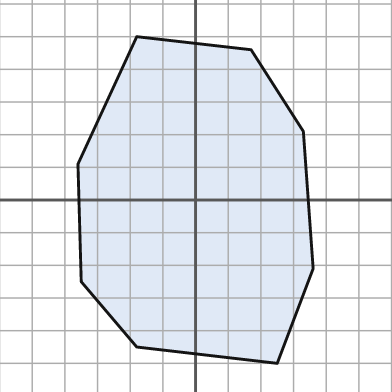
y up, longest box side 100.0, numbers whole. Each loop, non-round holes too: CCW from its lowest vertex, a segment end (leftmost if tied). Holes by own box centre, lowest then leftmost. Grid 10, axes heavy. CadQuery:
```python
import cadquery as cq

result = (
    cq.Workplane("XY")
    .moveTo(25.0, -50.0)
    .lineTo(36.0, -21.0)
    .lineTo(33.0, 21.0)
    .lineTo(17.0, 46.0)
    .lineTo(-18.0, 50.0)
    .lineTo(-36.0, 11.0)
    .lineTo(-35.0, -25.0)
    .lineTo(-18.0, -45.0)
    .close()
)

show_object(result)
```